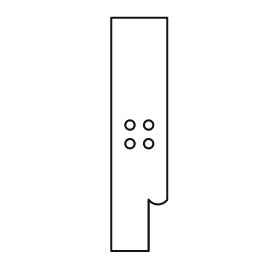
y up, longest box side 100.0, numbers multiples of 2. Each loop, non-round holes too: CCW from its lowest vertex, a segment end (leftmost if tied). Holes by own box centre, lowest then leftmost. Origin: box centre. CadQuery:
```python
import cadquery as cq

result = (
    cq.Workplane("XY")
    .moveTo(-12.0, -50.0)
    .lineTo(4.0, -50.0)
    .lineTo(4.0, -28.0)
    .threePointArc((8.0, -30.0), (12.0, -28.0))
    .lineTo(12.0, 50.0)
    .lineTo(-12.0, 50.0)
    .close()
    .moveTo(-4.0, -4.0)
    .circle(2.0)
    .moveTo(4.0, -4.0)
    .circle(2.0)
    .moveTo(-4.0, 4.0)
    .circle(2.0)
    .moveTo(4.0, 4.0)
    .circle(2.0)
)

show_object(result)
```